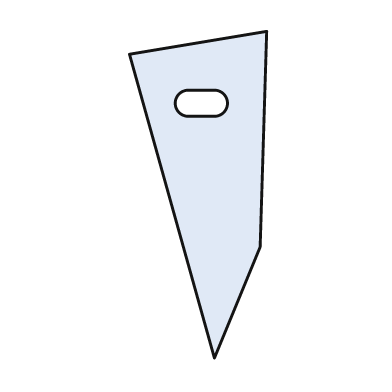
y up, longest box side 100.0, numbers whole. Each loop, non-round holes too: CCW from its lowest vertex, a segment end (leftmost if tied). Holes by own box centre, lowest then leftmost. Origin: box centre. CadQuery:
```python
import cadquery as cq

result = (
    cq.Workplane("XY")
    .moveTo(5.0, -50.0)
    .lineTo(19.0, -16.0)
    .lineTo(21.0, 50.0)
    .lineTo(-21.0, 43.0)
    .close()
    .moveTo(-3.0, 24.0)
    .lineTo(5.0, 24.0)
    .threePointArc((9.0, 28.0), (5.0, 32.0))
    .lineTo(-3.0, 32.0)
    .threePointArc((-7.0, 28.0), (-3.0, 24.0))
    .close()
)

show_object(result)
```